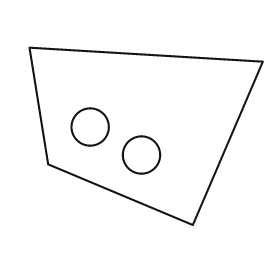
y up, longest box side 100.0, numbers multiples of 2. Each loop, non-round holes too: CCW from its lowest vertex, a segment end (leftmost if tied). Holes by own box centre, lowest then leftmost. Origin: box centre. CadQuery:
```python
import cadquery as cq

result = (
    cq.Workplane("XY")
    .moveTo(20.0, -38.0)
    .lineTo(50.0, 32.0)
    .lineTo(-50.0, 38.0)
    .lineTo(-42.0, -12.0)
    .close()
    .moveTo(-2.0, -8.0)
    .circle(8.0)
    .moveTo(-24.0, 4.0)
    .circle(8.0)
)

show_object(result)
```